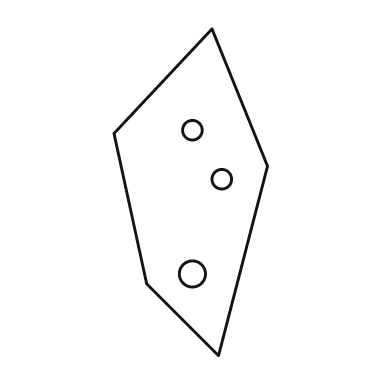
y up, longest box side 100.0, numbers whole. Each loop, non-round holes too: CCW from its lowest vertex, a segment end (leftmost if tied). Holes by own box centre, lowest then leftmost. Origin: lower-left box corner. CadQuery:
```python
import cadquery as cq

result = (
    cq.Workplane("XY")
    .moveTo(32.0, 0.0)
    .lineTo(47.0, 58.0)
    .lineTo(30.0, 100.0)
    .lineTo(0.0, 68.0)
    .lineTo(10.0, 22.0)
    .close()
    .moveTo(24.0, 25.0)
    .circle(4.0)
    .moveTo(33.0, 54.0)
    .circle(3.0)
    .moveTo(24.0, 69.0)
    .circle(3.0)
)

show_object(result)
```